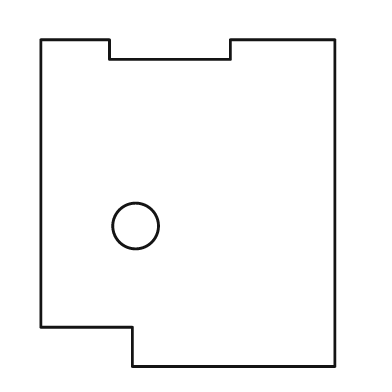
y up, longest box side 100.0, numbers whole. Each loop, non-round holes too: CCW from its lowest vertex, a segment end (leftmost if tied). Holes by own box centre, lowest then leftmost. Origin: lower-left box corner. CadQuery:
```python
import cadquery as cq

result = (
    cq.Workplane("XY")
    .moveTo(28.0, 0.0)
    .lineTo(90.0, 0.0)
    .lineTo(90.0, 100.0)
    .lineTo(58.0, 100.0)
    .lineTo(58.0, 94.0)
    .lineTo(21.0, 94.0)
    .lineTo(21.0, 100.0)
    .lineTo(0.0, 100.0)
    .lineTo(0.0, 12.0)
    .lineTo(28.0, 12.0)
    .close()
    .moveTo(29.0, 43.0)
    .circle(7.0)
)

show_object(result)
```